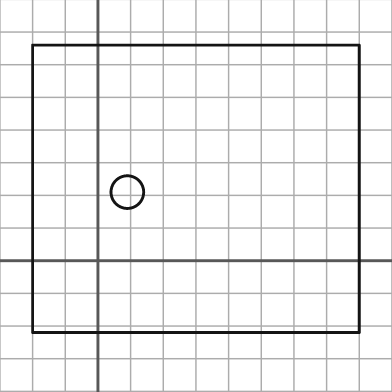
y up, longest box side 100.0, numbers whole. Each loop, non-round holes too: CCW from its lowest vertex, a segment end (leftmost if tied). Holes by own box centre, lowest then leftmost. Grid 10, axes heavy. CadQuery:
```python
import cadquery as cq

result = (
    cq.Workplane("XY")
    .moveTo(-20.0, -22.0)
    .lineTo(80.0, -22.0)
    .lineTo(80.0, 66.0)
    .lineTo(-20.0, 66.0)
    .close()
    .moveTo(9.0, 21.0)
    .circle(5.0)
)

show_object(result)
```